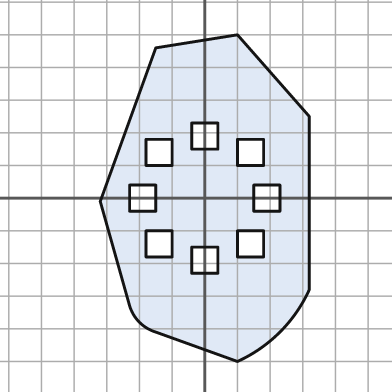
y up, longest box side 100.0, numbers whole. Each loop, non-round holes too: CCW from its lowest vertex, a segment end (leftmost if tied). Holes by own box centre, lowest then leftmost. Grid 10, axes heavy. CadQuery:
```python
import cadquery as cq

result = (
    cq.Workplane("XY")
    .moveTo(10.0, -50.0)
    .threePointArc((23.0, -41.0), (32.0, -28.0))
    .lineTo(32.0, 25.0)
    .lineTo(10.0, 50.0)
    .lineTo(-15.0, 46.0)
    .lineTo(-32.0, -1.0)
    .lineTo(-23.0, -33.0)
    .threePointArc((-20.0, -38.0), (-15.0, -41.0))
    .close()
    .moveTo(-4.0, -23.0)
    .lineTo(4.0, -23.0)
    .lineTo(4.0, -15.0)
    .lineTo(-4.0, -15.0)
    .close()
    .moveTo(-18.0, -18.0)
    .lineTo(-10.0, -18.0)
    .lineTo(-10.0, -10.0)
    .lineTo(-18.0, -10.0)
    .close()
    .moveTo(10.0, -18.0)
    .lineTo(18.0, -18.0)
    .lineTo(18.0, -10.0)
    .lineTo(10.0, -10.0)
    .close()
    .moveTo(-23.0, -4.0)
    .lineTo(-15.0, -4.0)
    .lineTo(-15.0, 4.0)
    .lineTo(-23.0, 4.0)
    .close()
    .moveTo(15.0, -4.0)
    .lineTo(23.0, -4.0)
    .lineTo(23.0, 4.0)
    .lineTo(15.0, 4.0)
    .close()
    .moveTo(-18.0, 10.0)
    .lineTo(-10.0, 10.0)
    .lineTo(-10.0, 18.0)
    .lineTo(-18.0, 18.0)
    .close()
    .moveTo(10.0, 10.0)
    .lineTo(18.0, 10.0)
    .lineTo(18.0, 18.0)
    .lineTo(10.0, 18.0)
    .close()
    .moveTo(-4.0, 15.0)
    .lineTo(4.0, 15.0)
    .lineTo(4.0, 23.0)
    .lineTo(-4.0, 23.0)
    .close()
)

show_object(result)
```